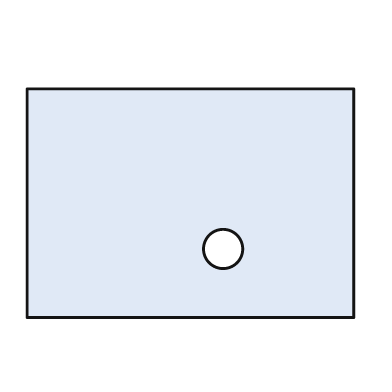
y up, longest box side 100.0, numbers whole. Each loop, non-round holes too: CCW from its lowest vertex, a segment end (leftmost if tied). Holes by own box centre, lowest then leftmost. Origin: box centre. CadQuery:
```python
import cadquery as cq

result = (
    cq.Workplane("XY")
    .moveTo(-50.0, -35.0)
    .lineTo(50.0, -35.0)
    .lineTo(50.0, 35.0)
    .lineTo(-50.0, 35.0)
    .close()
    .moveTo(10.0, -14.0)
    .circle(6.0)
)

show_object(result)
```